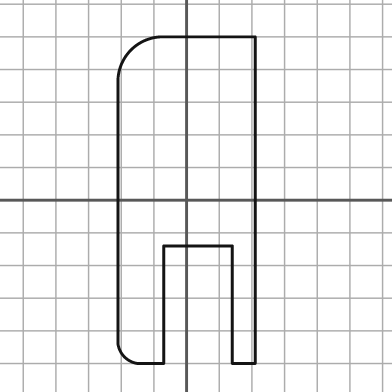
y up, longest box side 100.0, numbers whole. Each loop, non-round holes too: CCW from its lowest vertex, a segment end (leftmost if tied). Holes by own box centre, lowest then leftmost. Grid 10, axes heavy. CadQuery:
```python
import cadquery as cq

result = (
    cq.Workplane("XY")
    .moveTo(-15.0, -50.0)
    .lineTo(-7.0, -50.0)
    .lineTo(-7.0, -14.0)
    .lineTo(14.0, -14.0)
    .lineTo(14.0, -50.0)
    .lineTo(21.0, -50.0)
    .lineTo(21.0, 50.0)
    .lineTo(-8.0, 50.0)
    .threePointArc((-17.0, 46.0), (-21.0, 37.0))
    .lineTo(-21.0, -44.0)
    .threePointArc((-19.0, -48.0), (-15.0, -50.0))
    .close()
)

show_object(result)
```